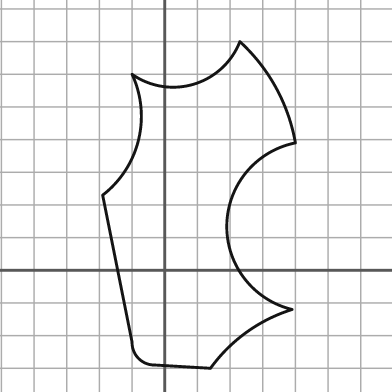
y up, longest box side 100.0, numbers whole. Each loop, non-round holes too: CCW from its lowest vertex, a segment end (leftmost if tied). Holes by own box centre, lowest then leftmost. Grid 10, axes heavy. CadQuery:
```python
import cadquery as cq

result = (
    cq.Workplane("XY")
    .moveTo(14.0, -30.0)
    .threePointArc((25.0, -19.0), (39.0, -12.0))
    .threePointArc((19.0, 14.0), (40.0, 39.0))
    .threePointArc((34.0, 56.0), (23.0, 70.0))
    .threePointArc((9.0, 57.0), (-10.0, 60.0))
    .threePointArc((-8.0, 40.0), (-19.0, 23.0))
    .lineTo(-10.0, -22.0)
    .threePointArc((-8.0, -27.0), (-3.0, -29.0))
    .close()
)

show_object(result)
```